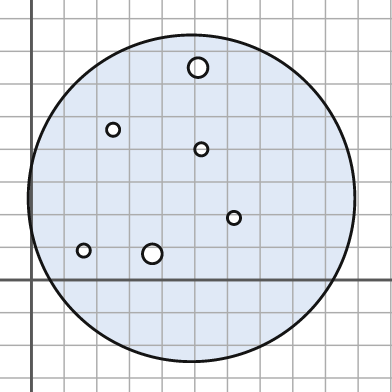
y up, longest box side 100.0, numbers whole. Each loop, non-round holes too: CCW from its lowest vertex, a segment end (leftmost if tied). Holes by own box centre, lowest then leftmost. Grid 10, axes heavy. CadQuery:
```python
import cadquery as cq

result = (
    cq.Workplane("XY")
    .moveTo(49.0, 25.0)
    .circle(50.0)
    .moveTo(37.0, 8.0)
    .circle(3.0)
    .moveTo(16.0, 9.0)
    .circle(2.0)
    .moveTo(62.0, 19.0)
    .circle(2.0)
    .moveTo(52.0, 40.0)
    .circle(2.0)
    .moveTo(25.0, 46.0)
    .circle(2.0)
    .moveTo(51.0, 65.0)
    .circle(3.0)
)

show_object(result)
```